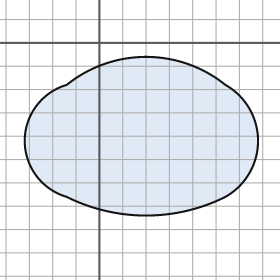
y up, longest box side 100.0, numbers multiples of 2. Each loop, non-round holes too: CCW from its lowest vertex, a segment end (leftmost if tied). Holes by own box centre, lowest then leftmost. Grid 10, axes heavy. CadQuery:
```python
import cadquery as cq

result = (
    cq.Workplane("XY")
    .moveTo(-14.0, -66.0)
    .threePointArc((20.0, -74.0), (54.0, -66.0))
    .threePointArc((68.0, -42.0), (54.0, -18.0))
    .threePointArc((20.0, -6.0), (-14.0, -18.0))
    .threePointArc((-32.0, -42.0), (-14.0, -66.0))
    .close()
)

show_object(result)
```